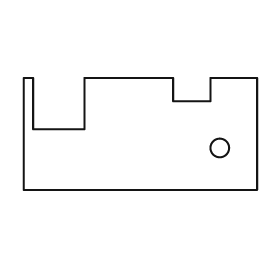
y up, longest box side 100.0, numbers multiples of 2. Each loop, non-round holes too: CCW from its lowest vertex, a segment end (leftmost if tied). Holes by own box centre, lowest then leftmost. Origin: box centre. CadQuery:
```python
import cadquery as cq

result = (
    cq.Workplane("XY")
    .moveTo(-50.0, -24.0)
    .lineTo(50.0, -24.0)
    .lineTo(50.0, 24.0)
    .lineTo(30.0, 24.0)
    .lineTo(30.0, 14.0)
    .lineTo(14.0, 14.0)
    .lineTo(14.0, 24.0)
    .lineTo(-24.0, 24.0)
    .lineTo(-24.0, 2.0)
    .lineTo(-46.0, 2.0)
    .lineTo(-46.0, 24.0)
    .lineTo(-50.0, 24.0)
    .close()
    .moveTo(34.0, -6.0)
    .circle(4.0)
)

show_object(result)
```